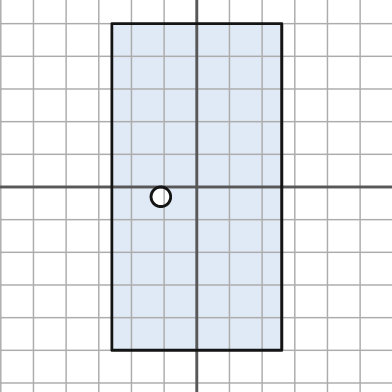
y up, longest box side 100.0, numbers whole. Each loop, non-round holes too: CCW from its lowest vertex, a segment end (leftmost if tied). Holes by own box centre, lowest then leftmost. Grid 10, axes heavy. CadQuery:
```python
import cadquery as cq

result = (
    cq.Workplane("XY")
    .moveTo(-26.0, -50.0)
    .lineTo(26.0, -50.0)
    .lineTo(26.0, 50.0)
    .lineTo(-26.0, 50.0)
    .close()
    .moveTo(-11.0, -3.0)
    .circle(3.0)
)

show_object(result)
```